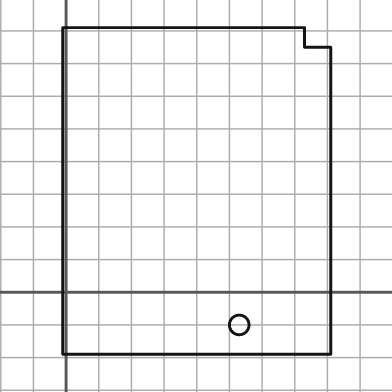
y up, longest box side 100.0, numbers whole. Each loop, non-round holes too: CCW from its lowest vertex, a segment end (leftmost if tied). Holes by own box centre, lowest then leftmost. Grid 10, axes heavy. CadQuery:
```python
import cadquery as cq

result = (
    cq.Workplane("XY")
    .moveTo(-1.0, -19.0)
    .lineTo(81.0, -19.0)
    .lineTo(81.0, 75.0)
    .lineTo(73.0, 75.0)
    .lineTo(73.0, 81.0)
    .lineTo(-1.0, 81.0)
    .close()
    .moveTo(53.0, -10.0)
    .circle(3.0)
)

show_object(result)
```